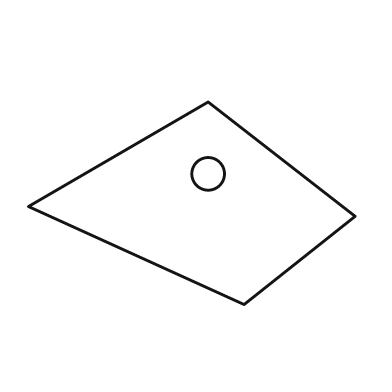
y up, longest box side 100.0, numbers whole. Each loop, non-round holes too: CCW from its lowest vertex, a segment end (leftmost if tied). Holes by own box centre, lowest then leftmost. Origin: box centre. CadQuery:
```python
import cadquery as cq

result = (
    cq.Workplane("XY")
    .moveTo(16.0, -31.0)
    .lineTo(50.0, -4.0)
    .lineTo(5.0, 31.0)
    .lineTo(-50.0, -1.0)
    .close()
    .moveTo(5.0, 9.0)
    .circle(5.0)
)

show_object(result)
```